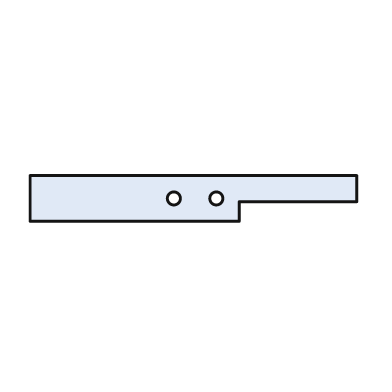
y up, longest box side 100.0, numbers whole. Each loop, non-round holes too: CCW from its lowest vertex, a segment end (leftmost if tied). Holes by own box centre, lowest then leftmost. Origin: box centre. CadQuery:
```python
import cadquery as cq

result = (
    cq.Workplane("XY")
    .moveTo(-50.0, -7.0)
    .lineTo(14.0, -7.0)
    .lineTo(14.0, -1.0)
    .lineTo(50.0, -1.0)
    .lineTo(50.0, 7.0)
    .lineTo(-50.0, 7.0)
    .close()
    .moveTo(-6.0, 0.0)
    .circle(2.0)
    .moveTo(7.0, 0.0)
    .circle(2.0)
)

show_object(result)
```